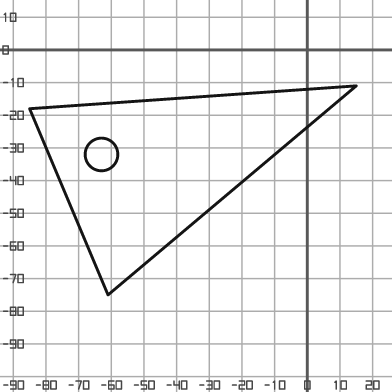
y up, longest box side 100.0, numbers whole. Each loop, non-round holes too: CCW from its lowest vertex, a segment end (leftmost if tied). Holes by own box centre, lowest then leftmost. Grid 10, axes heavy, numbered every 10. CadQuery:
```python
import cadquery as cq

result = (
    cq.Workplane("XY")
    .moveTo(-61.0, -75.0)
    .lineTo(15.0, -11.0)
    .lineTo(-85.0, -18.0)
    .close()
    .moveTo(-63.0, -32.0)
    .circle(5.0)
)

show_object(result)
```